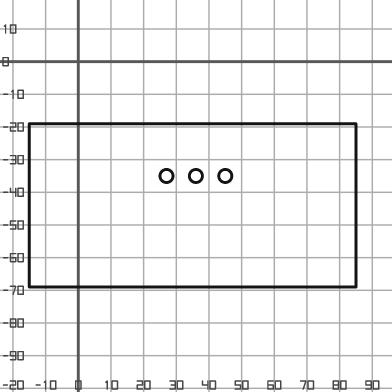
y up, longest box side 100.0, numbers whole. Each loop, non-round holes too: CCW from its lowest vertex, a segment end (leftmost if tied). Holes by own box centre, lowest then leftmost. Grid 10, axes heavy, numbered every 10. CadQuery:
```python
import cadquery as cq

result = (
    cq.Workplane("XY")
    .moveTo(-15.0, -69.0)
    .lineTo(85.0, -69.0)
    .lineTo(85.0, -19.0)
    .lineTo(-15.0, -19.0)
    .close()
    .moveTo(27.0, -35.0)
    .circle(2.0)
    .moveTo(36.0, -35.0)
    .circle(2.0)
    .moveTo(45.0, -35.0)
    .circle(2.0)
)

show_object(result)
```